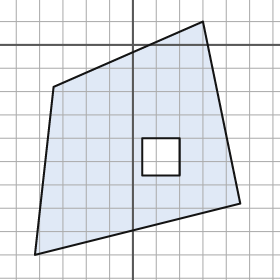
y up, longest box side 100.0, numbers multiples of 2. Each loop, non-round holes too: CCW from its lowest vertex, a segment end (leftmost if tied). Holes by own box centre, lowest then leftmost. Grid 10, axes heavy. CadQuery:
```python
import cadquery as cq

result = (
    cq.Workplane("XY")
    .moveTo(-42.0, -90.0)
    .lineTo(46.0, -68.0)
    .lineTo(30.0, 10.0)
    .lineTo(-34.0, -18.0)
    .close()
    .moveTo(4.0, -56.0)
    .lineTo(20.0, -56.0)
    .lineTo(20.0, -40.0)
    .lineTo(4.0, -40.0)
    .close()
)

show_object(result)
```